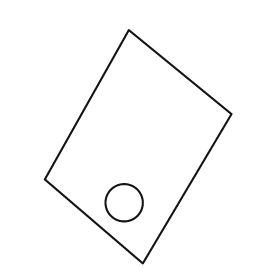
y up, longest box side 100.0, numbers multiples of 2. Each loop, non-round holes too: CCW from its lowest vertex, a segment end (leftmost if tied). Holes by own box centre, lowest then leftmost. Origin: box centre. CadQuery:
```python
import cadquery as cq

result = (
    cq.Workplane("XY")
    .moveTo(2.0, -50.0)
    .lineTo(40.0, 14.0)
    .lineTo(-4.0, 50.0)
    .lineTo(-40.0, -14.0)
    .close()
    .moveTo(-6.0, -24.0)
    .circle(8.0)
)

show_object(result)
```